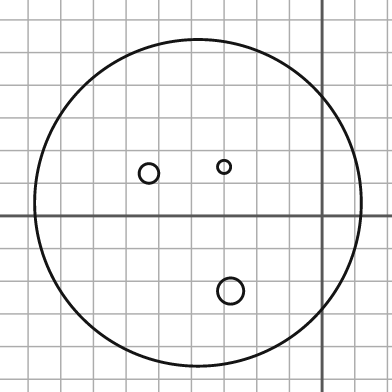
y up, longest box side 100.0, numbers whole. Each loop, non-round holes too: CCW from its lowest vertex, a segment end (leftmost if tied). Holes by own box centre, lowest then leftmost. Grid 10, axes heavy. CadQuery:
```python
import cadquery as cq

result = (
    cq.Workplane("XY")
    .moveTo(-38.0, 4.0)
    .circle(50.0)
    .moveTo(-28.0, -23.0)
    .circle(4.0)
    .moveTo(-53.0, 13.0)
    .circle(3.0)
    .moveTo(-30.0, 15.0)
    .circle(2.0)
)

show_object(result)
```